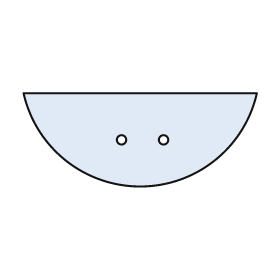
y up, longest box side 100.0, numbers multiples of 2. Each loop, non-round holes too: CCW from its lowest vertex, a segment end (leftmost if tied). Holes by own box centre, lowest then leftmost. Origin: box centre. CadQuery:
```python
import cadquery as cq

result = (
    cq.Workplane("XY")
    .moveTo(-50.0, 20.0)
    .threePointArc((0.0, -20.0), (50.0, 20.0))
    .close()
    .moveTo(-8.0, 0.0)
    .circle(2.0)
    .moveTo(10.0, 0.0)
    .circle(2.0)
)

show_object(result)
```